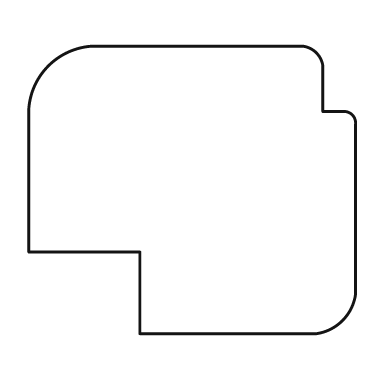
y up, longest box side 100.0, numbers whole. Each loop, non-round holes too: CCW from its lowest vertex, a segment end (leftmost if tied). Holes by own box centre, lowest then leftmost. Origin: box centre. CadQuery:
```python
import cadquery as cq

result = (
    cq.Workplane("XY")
    .moveTo(-16.0, -44.0)
    .lineTo(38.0, -44.0)
    .threePointArc((46.0, -40.0), (50.0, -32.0))
    .lineTo(50.0, 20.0)
    .threePointArc((49.0, 23.0), (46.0, 24.0))
    .lineTo(40.0, 24.0)
    .lineTo(40.0, 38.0)
    .threePointArc((38.0, 42.0), (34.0, 44.0))
    .lineTo(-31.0, 44.0)
    .threePointArc((-44.0, 38.0), (-50.0, 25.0))
    .lineTo(-50.0, -19.0)
    .lineTo(-16.0, -19.0)
    .close()
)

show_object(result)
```